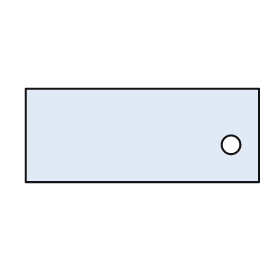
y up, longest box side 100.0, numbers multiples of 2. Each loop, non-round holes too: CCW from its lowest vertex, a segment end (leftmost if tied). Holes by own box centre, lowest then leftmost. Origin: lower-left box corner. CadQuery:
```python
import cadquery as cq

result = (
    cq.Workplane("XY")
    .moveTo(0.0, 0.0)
    .lineTo(100.0, 0.0)
    .lineTo(100.0, 40.0)
    .lineTo(0.0, 40.0)
    .close()
    .moveTo(88.0, 16.0)
    .circle(4.0)
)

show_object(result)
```